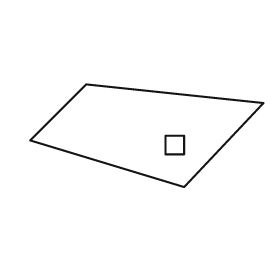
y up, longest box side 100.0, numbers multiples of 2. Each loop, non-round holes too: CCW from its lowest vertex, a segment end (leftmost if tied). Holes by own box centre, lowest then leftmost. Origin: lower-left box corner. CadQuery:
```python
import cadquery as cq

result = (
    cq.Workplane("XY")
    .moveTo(66.0, 0.0)
    .lineTo(100.0, 36.0)
    .lineTo(24.0, 44.0)
    .lineTo(0.0, 20.0)
    .close()
    .moveTo(58.0, 14.0)
    .lineTo(66.0, 14.0)
    .lineTo(66.0, 22.0)
    .lineTo(58.0, 22.0)
    .close()
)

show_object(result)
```